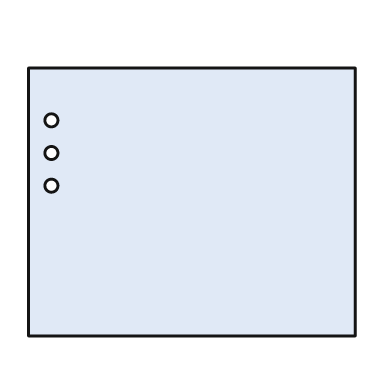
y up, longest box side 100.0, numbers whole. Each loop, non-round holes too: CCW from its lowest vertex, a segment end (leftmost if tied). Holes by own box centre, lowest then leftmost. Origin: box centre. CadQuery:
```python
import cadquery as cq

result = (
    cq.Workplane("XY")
    .moveTo(-50.0, -41.0)
    .lineTo(50.0, -41.0)
    .lineTo(50.0, 41.0)
    .lineTo(-50.0, 41.0)
    .close()
    .moveTo(-43.0, 5.0)
    .circle(2.0)
    .moveTo(-43.0, 15.0)
    .circle(2.0)
    .moveTo(-43.0, 25.0)
    .circle(2.0)
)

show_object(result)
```